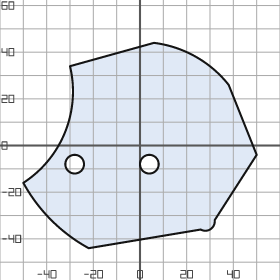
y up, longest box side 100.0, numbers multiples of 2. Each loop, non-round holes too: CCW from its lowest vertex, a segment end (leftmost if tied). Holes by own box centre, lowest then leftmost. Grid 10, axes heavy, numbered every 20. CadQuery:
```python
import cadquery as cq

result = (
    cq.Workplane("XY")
    .moveTo(-22.0, -44.0)
    .lineTo(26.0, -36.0)
    .threePointArc((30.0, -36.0), (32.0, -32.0))
    .lineTo(50.0, -4.0)
    .lineTo(38.0, 26.0)
    .threePointArc((24.0, 38.0), (6.0, 44.0))
    .lineTo(-30.0, 34.0)
    .threePointArc((-32.0, 6.0), (-50.0, -16.0))
    .threePointArc((-38.0, -32.0), (-22.0, -44.0))
    .close()
    .moveTo(-28.0, -8.0)
    .circle(4.0)
    .moveTo(4.0, -8.0)
    .circle(4.0)
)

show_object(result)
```